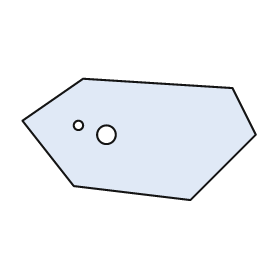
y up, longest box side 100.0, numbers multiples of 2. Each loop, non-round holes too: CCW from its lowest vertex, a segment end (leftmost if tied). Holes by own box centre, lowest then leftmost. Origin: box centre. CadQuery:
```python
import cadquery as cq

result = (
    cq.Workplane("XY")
    .moveTo(22.0, -26.0)
    .lineTo(50.0, 2.0)
    .lineTo(40.0, 22.0)
    .lineTo(-24.0, 26.0)
    .lineTo(-50.0, 8.0)
    .lineTo(-28.0, -20.0)
    .close()
    .moveTo(-14.0, 2.0)
    .circle(4.0)
    .moveTo(-26.0, 6.0)
    .circle(2.0)
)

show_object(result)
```